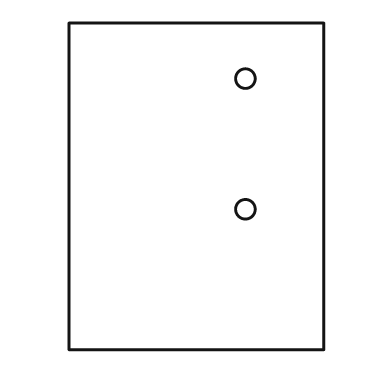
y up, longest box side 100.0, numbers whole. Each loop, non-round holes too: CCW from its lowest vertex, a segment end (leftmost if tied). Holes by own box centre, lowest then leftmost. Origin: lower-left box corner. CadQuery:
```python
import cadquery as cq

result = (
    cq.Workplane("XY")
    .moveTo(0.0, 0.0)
    .lineTo(78.0, 0.0)
    .lineTo(78.0, 100.0)
    .lineTo(0.0, 100.0)
    .close()
    .moveTo(54.0, 43.0)
    .circle(3.0)
    .moveTo(54.0, 83.0)
    .circle(3.0)
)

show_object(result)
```